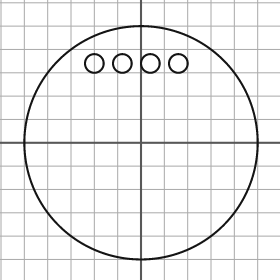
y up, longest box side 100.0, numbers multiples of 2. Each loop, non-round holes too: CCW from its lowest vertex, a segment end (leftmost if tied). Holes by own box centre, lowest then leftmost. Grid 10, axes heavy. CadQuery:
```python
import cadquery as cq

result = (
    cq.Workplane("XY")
    .moveTo(0.0, 0.0)
    .circle(50.0)
    .moveTo(-20.0, 34.0)
    .circle(4.0)
    .moveTo(-8.0, 34.0)
    .circle(4.0)
    .moveTo(4.0, 34.0)
    .circle(4.0)
    .moveTo(16.0, 34.0)
    .circle(4.0)
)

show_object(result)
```